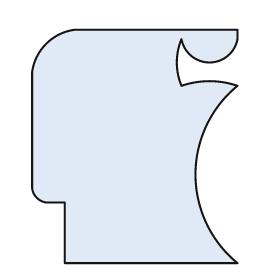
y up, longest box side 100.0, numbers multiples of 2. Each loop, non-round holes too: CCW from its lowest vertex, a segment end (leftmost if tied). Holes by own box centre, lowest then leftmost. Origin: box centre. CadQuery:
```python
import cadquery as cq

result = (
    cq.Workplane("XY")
    .moveTo(-30.0, -50.0)
    .lineTo(44.0, -50.0)
    .threePointArc((26.0, -12.0), (44.0, 26.0))
    .threePointArc((32.0, 28.0), (20.0, 26.0))
    .threePointArc((18.0, 36.0), (20.0, 46.0))
    .threePointArc((32.0, 36.0), (44.0, 46.0))
    .lineTo(44.0, 50.0)
    .lineTo(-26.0, 50.0)
    .threePointArc((-38.0, 44.0), (-44.0, 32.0))
    .lineTo(-44.0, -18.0)
    .threePointArc((-42.0, -22.0), (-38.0, -24.0))
    .lineTo(-30.0, -24.0)
    .close()
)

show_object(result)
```